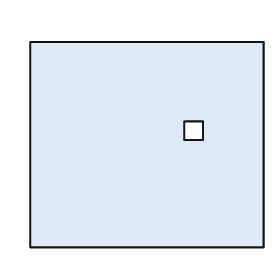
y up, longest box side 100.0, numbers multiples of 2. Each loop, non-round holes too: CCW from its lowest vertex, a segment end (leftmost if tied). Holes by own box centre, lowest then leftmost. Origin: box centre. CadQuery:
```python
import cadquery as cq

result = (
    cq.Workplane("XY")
    .moveTo(-50.0, -44.0)
    .lineTo(50.0, -44.0)
    .lineTo(50.0, 44.0)
    .lineTo(-50.0, 44.0)
    .close()
    .moveTo(16.0, 2.0)
    .lineTo(24.0, 2.0)
    .lineTo(24.0, 10.0)
    .lineTo(16.0, 10.0)
    .close()
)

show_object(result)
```